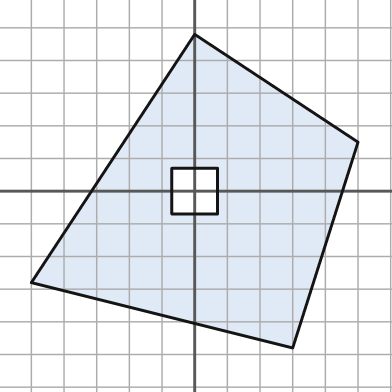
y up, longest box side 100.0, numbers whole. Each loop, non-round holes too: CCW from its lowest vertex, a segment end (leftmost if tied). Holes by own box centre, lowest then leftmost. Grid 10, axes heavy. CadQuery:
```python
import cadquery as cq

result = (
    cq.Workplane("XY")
    .moveTo(30.0, -48.0)
    .lineTo(50.0, 15.0)
    .lineTo(0.0, 48.0)
    .lineTo(-50.0, -28.0)
    .close()
    .moveTo(-7.0, -7.0)
    .lineTo(7.0, -7.0)
    .lineTo(7.0, 7.0)
    .lineTo(-7.0, 7.0)
    .close()
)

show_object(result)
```